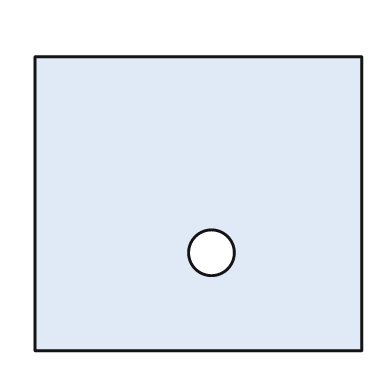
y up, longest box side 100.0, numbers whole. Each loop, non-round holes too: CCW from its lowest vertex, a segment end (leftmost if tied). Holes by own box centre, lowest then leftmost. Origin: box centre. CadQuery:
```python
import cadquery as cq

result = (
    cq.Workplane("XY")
    .moveTo(-50.0, -45.0)
    .lineTo(50.0, -45.0)
    .lineTo(50.0, 45.0)
    .lineTo(-50.0, 45.0)
    .close()
    .moveTo(4.0, -15.0)
    .circle(7.0)
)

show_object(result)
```